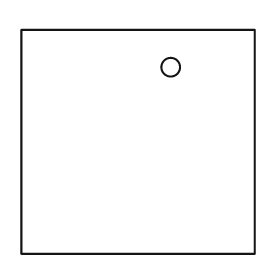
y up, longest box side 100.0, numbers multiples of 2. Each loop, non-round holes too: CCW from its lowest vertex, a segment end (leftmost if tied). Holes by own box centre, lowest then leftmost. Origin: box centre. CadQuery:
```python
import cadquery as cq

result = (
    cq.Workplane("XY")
    .moveTo(-50.0, -48.0)
    .lineTo(50.0, -48.0)
    .lineTo(50.0, 48.0)
    .lineTo(-50.0, 48.0)
    .close()
    .moveTo(14.0, 32.0)
    .circle(4.0)
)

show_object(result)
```